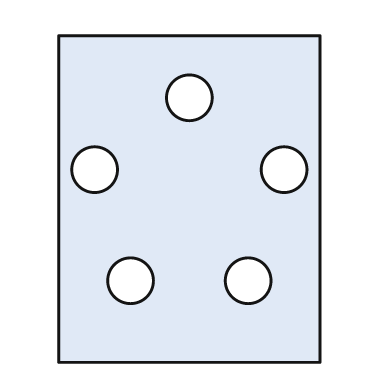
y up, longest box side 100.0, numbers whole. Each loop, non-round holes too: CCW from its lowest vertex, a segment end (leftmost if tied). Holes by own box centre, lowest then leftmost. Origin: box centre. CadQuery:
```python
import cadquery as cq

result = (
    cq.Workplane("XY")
    .moveTo(-40.0, -50.0)
    .lineTo(40.0, -50.0)
    .lineTo(40.0, 50.0)
    .lineTo(-40.0, 50.0)
    .close()
    .moveTo(-18.0, -25.0)
    .circle(7.0)
    .moveTo(18.0, -25.0)
    .circle(7.0)
    .moveTo(-29.0, 9.0)
    .circle(7.0)
    .moveTo(29.0, 9.0)
    .circle(7.0)
    .moveTo(0.0, 31.0)
    .circle(7.0)
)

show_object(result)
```